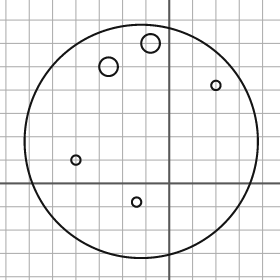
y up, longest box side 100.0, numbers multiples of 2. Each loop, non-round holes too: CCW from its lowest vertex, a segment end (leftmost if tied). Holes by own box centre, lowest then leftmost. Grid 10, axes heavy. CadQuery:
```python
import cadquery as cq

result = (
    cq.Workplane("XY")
    .moveTo(-12.0, 18.0)
    .circle(50.0)
    .moveTo(-14.0, -8.0)
    .circle(2.0)
    .moveTo(-40.0, 10.0)
    .circle(2.0)
    .moveTo(20.0, 42.0)
    .circle(2.0)
    .moveTo(-26.0, 50.0)
    .circle(4.0)
    .moveTo(-8.0, 60.0)
    .circle(4.0)
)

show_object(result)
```